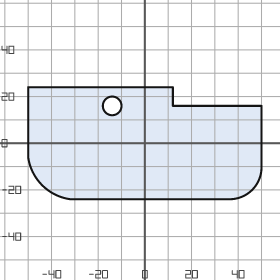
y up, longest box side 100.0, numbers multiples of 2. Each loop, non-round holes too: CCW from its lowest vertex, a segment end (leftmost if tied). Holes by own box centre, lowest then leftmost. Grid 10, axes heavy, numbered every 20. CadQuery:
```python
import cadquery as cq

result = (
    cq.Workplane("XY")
    .moveTo(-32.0, -24.0)
    .lineTo(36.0, -24.0)
    .threePointArc((46.0, -20.0), (50.0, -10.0))
    .lineTo(50.0, 16.0)
    .lineTo(12.0, 16.0)
    .lineTo(12.0, 24.0)
    .lineTo(-50.0, 24.0)
    .lineTo(-50.0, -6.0)
    .threePointArc((-44.0, -18.0), (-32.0, -24.0))
    .close()
    .moveTo(-14.0, 16.0)
    .circle(4.0)
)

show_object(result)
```